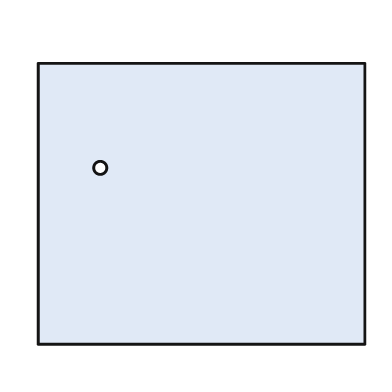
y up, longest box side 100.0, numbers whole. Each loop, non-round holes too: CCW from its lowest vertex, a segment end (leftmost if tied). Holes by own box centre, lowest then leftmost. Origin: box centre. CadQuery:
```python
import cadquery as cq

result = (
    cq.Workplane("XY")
    .moveTo(-50.0, -43.0)
    .lineTo(50.0, -43.0)
    .lineTo(50.0, 43.0)
    .lineTo(-50.0, 43.0)
    .close()
    .moveTo(-31.0, 11.0)
    .circle(2.0)
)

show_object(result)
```